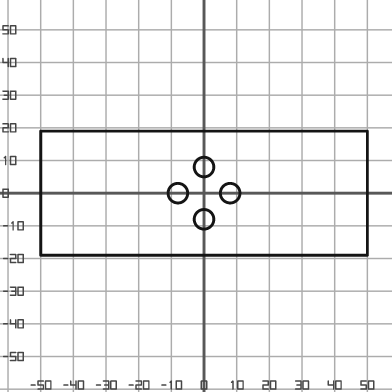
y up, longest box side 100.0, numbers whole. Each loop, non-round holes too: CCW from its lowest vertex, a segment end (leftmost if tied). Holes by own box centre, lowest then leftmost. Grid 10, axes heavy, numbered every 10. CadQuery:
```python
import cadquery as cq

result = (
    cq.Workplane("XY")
    .moveTo(-50.0, -19.0)
    .lineTo(50.0, -19.0)
    .lineTo(50.0, 19.0)
    .lineTo(-50.0, 19.0)
    .close()
    .moveTo(0.0, -8.0)
    .circle(3.0)
    .moveTo(-8.0, 0.0)
    .circle(3.0)
    .moveTo(8.0, 0.0)
    .circle(3.0)
    .moveTo(0.0, 8.0)
    .circle(3.0)
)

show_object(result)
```